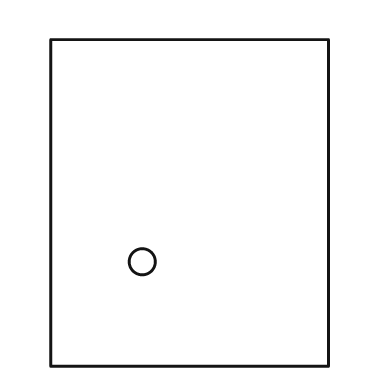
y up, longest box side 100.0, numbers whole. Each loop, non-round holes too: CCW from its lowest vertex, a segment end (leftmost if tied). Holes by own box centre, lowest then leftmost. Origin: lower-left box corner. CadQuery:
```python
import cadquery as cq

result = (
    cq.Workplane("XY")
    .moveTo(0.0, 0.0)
    .lineTo(85.0, 0.0)
    .lineTo(85.0, 100.0)
    .lineTo(0.0, 100.0)
    .close()
    .moveTo(28.0, 32.0)
    .circle(4.0)
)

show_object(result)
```